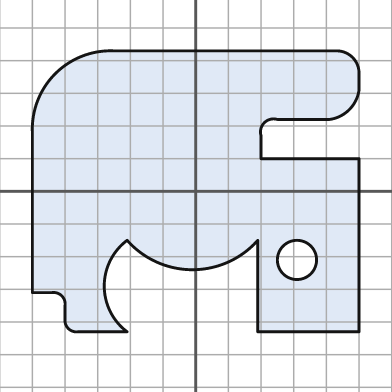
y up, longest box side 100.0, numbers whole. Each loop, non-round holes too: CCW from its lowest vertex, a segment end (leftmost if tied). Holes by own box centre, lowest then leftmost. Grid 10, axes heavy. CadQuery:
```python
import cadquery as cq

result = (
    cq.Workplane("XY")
    .moveTo(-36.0, -43.0)
    .lineTo(-21.0, -43.0)
    .threePointArc((-28.0, -29.0), (-21.0, -15.0))
    .threePointArc((-1.0, -24.0), (19.0, -15.0))
    .lineTo(19.0, -43.0)
    .lineTo(50.0, -43.0)
    .lineTo(50.0, 10.0)
    .lineTo(20.0, 10.0)
    .lineTo(20.0, 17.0)
    .threePointArc((21.0, 21.0), (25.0, 22.0))
    .lineTo(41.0, 22.0)
    .threePointArc((47.0, 25.0), (50.0, 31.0))
    .lineTo(50.0, 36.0)
    .threePointArc((48.0, 41.0), (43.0, 43.0))
    .lineTo(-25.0, 43.0)
    .threePointArc((-43.0, 36.0), (-50.0, 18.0))
    .lineTo(-50.0, -31.0)
    .lineTo(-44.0, -31.0)
    .threePointArc((-41.0, -32.0), (-40.0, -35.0))
    .lineTo(-40.0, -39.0)
    .threePointArc((-39.0, -42.0), (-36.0, -43.0))
    .close()
    .moveTo(31.0, -21.0)
    .circle(6.0)
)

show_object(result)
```